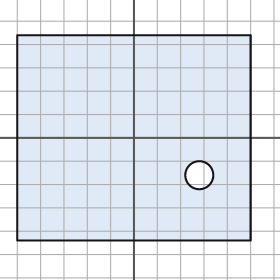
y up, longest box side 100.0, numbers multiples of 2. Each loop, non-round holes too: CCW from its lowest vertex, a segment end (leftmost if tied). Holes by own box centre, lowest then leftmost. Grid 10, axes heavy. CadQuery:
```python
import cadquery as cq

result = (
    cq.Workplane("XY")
    .moveTo(-50.0, -44.0)
    .lineTo(50.0, -44.0)
    .lineTo(50.0, 44.0)
    .lineTo(-50.0, 44.0)
    .close()
    .moveTo(28.0, -16.0)
    .circle(6.0)
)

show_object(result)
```